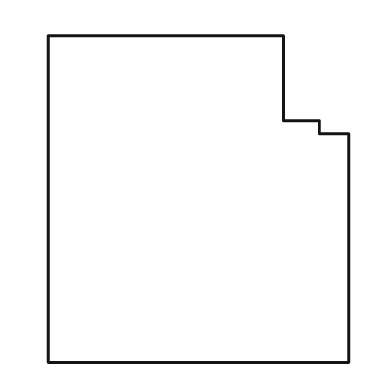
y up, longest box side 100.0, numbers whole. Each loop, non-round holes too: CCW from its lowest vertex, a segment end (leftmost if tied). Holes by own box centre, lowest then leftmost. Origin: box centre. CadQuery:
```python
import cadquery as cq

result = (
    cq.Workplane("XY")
    .moveTo(-46.0, -50.0)
    .lineTo(46.0, -50.0)
    .lineTo(46.0, 20.0)
    .lineTo(37.0, 20.0)
    .lineTo(37.0, 24.0)
    .lineTo(26.0, 24.0)
    .lineTo(26.0, 50.0)
    .lineTo(-46.0, 50.0)
    .close()
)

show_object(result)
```